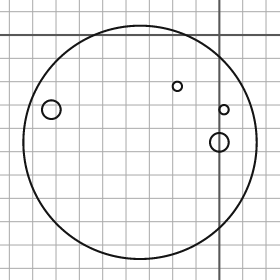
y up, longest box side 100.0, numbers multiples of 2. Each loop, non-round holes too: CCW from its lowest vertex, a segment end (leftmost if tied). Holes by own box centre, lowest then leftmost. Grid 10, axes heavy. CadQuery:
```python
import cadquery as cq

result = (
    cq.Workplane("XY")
    .moveTo(-34.0, -46.0)
    .circle(50.0)
    .moveTo(0.0, -46.0)
    .circle(4.0)
    .moveTo(-72.0, -32.0)
    .circle(4.0)
    .moveTo(2.0, -32.0)
    .circle(2.0)
    .moveTo(-18.0, -22.0)
    .circle(2.0)
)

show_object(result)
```